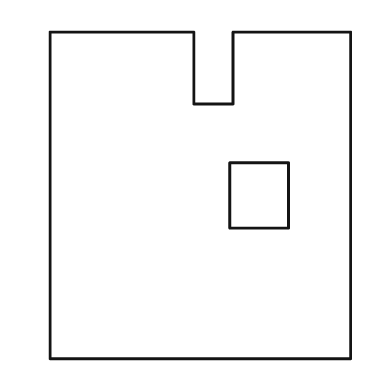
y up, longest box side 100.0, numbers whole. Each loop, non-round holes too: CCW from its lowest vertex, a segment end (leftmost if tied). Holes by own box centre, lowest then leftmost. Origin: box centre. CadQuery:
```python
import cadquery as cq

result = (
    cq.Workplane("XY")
    .moveTo(-46.0, -50.0)
    .lineTo(46.0, -50.0)
    .lineTo(46.0, 50.0)
    .lineTo(10.0, 50.0)
    .lineTo(10.0, 28.0)
    .lineTo(-2.0, 28.0)
    .lineTo(-2.0, 50.0)
    .lineTo(-46.0, 50.0)
    .close()
    .moveTo(9.0, -10.0)
    .lineTo(27.0, -10.0)
    .lineTo(27.0, 10.0)
    .lineTo(9.0, 10.0)
    .close()
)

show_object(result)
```